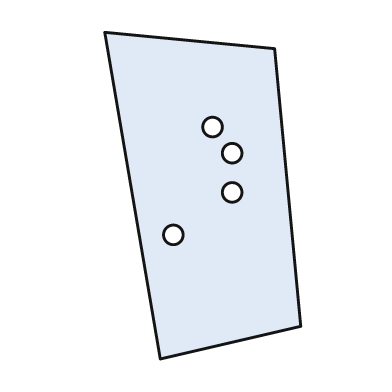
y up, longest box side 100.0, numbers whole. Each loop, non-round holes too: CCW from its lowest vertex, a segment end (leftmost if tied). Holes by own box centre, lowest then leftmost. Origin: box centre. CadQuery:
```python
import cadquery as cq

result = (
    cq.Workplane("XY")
    .moveTo(-13.0, -50.0)
    .lineTo(30.0, -40.0)
    .lineTo(22.0, 45.0)
    .lineTo(-30.0, 50.0)
    .close()
    .moveTo(-9.0, -12.0)
    .circle(3.0)
    .moveTo(9.0, 1.0)
    .circle(3.0)
    .moveTo(9.0, 13.0)
    .circle(3.0)
    .moveTo(3.0, 21.0)
    .circle(3.0)
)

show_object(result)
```